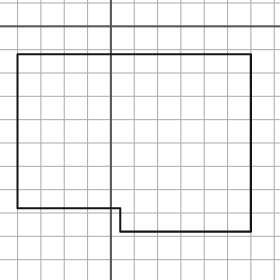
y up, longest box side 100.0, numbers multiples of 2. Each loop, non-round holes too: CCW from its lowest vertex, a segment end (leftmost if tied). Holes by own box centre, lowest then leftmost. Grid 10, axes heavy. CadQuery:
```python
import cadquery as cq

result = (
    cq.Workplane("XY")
    .moveTo(4.0, -88.0)
    .lineTo(60.0, -88.0)
    .lineTo(60.0, -12.0)
    .lineTo(-40.0, -12.0)
    .lineTo(-40.0, -78.0)
    .lineTo(4.0, -78.0)
    .close()
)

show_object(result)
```